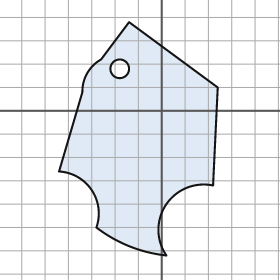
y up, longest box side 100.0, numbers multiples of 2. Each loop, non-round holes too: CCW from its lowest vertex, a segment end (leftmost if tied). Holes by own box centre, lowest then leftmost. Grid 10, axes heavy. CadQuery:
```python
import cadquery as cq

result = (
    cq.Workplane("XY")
    .moveTo(2.0, -62.0)
    .threePointArc((2.0, -40.0), (22.0, -32.0))
    .lineTo(24.0, 10.0)
    .lineTo(-14.0, 38.0)
    .lineTo(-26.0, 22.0)
    .threePointArc((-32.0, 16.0), (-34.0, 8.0))
    .lineTo(-44.0, -26.0)
    .threePointArc((-30.0, -34.0), (-28.0, -50.0))
    .threePointArc((-14.0, -58.0), (2.0, -62.0))
    .close()
    .moveTo(-18.0, 18.0)
    .circle(4.0)
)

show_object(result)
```